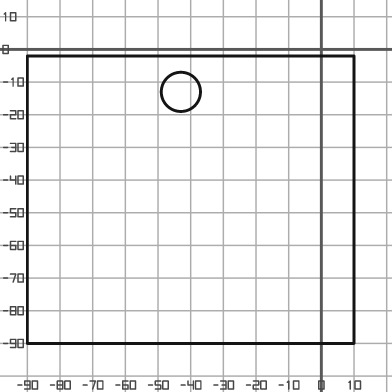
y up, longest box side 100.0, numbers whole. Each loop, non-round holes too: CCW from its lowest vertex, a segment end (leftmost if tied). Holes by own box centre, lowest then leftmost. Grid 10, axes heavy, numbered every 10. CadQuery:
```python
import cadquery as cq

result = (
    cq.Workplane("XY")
    .moveTo(-90.0, -90.0)
    .lineTo(10.0, -90.0)
    .lineTo(10.0, -2.0)
    .lineTo(-90.0, -2.0)
    .close()
    .moveTo(-43.0, -13.0)
    .circle(6.0)
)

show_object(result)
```